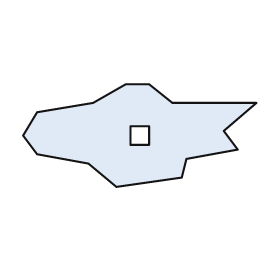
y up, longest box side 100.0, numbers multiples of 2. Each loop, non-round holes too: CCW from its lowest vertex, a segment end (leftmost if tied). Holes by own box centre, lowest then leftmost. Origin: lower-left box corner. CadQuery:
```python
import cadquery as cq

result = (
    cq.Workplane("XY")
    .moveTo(40.0, 0.0)
    .lineTo(68.0, 4.0)
    .lineTo(70.0, 12.0)
    .lineTo(92.0, 16.0)
    .lineTo(86.0, 24.0)
    .lineTo(100.0, 36.0)
    .lineTo(64.0, 36.0)
    .lineTo(54.0, 44.0)
    .lineTo(44.0, 44.0)
    .lineTo(30.0, 36.0)
    .lineTo(6.0, 32.0)
    .lineTo(0.0, 22.0)
    .lineTo(6.0, 14.0)
    .lineTo(28.0, 10.0)
    .close()
    .moveTo(46.0, 18.0)
    .lineTo(54.0, 18.0)
    .lineTo(54.0, 26.0)
    .lineTo(46.0, 26.0)
    .close()
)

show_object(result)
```